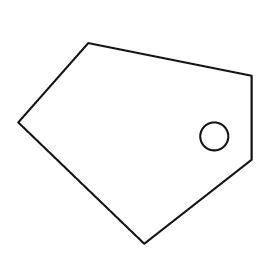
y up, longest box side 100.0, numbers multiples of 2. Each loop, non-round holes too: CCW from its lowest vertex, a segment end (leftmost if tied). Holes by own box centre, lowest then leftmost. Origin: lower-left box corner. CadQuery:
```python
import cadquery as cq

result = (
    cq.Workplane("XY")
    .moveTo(54.0, 0.0)
    .lineTo(100.0, 36.0)
    .lineTo(100.0, 72.0)
    .lineTo(30.0, 86.0)
    .lineTo(0.0, 52.0)
    .close()
    .moveTo(84.0, 46.0)
    .circle(6.0)
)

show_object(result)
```